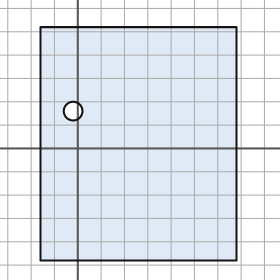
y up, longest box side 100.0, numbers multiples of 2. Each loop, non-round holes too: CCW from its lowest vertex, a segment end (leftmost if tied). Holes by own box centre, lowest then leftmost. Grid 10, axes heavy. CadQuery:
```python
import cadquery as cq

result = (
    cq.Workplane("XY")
    .moveTo(-16.0, -48.0)
    .lineTo(68.0, -48.0)
    .lineTo(68.0, 52.0)
    .lineTo(-16.0, 52.0)
    .close()
    .moveTo(-2.0, 16.0)
    .circle(4.0)
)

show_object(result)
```